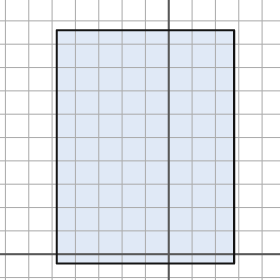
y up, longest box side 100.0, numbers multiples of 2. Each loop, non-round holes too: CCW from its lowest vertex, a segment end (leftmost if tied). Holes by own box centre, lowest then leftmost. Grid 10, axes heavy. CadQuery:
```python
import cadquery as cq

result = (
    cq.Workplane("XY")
    .moveTo(-48.0, -4.0)
    .lineTo(28.0, -4.0)
    .lineTo(28.0, 96.0)
    .lineTo(-48.0, 96.0)
    .close()
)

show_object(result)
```